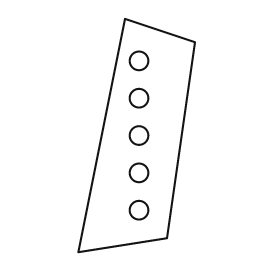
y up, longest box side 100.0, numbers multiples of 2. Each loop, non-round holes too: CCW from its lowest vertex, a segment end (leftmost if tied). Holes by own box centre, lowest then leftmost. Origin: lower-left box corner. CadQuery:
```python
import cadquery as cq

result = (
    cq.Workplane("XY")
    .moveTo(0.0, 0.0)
    .lineTo(38.0, 6.0)
    .lineTo(50.0, 90.0)
    .lineTo(20.0, 100.0)
    .close()
    .moveTo(26.0, 18.0)
    .circle(4.0)
    .moveTo(26.0, 34.0)
    .circle(4.0)
    .moveTo(26.0, 50.0)
    .circle(4.0)
    .moveTo(26.0, 66.0)
    .circle(4.0)
    .moveTo(26.0, 82.0)
    .circle(4.0)
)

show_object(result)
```